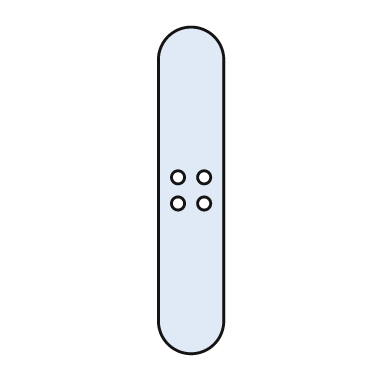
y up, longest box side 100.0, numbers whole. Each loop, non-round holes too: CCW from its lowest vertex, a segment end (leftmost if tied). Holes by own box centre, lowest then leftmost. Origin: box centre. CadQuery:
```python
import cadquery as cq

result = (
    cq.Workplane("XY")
    .moveTo(-10.0, -40.0)
    .threePointArc((0.0, -50.0), (10.0, -40.0))
    .lineTo(10.0, 40.0)
    .threePointArc((0.0, 50.0), (-10.0, 40.0))
    .close()
    .moveTo(-4.0, -4.0)
    .circle(2.0)
    .moveTo(4.0, -4.0)
    .circle(2.0)
    .moveTo(-4.0, 4.0)
    .circle(2.0)
    .moveTo(4.0, 4.0)
    .circle(2.0)
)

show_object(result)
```